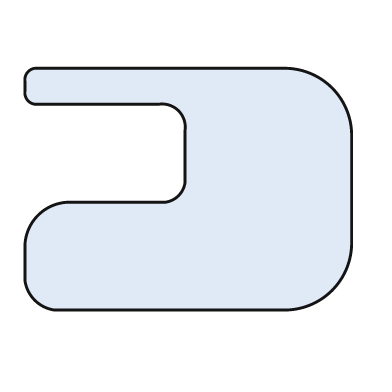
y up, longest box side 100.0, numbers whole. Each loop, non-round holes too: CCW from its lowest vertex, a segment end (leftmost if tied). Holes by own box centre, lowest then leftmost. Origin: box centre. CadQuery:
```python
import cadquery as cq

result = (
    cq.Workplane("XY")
    .moveTo(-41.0, -37.0)
    .lineTo(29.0, -37.0)
    .threePointArc((44.0, -31.0), (50.0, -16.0))
    .lineTo(50.0, 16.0)
    .threePointArc((44.0, 31.0), (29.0, 37.0))
    .lineTo(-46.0, 37.0)
    .threePointArc((-49.0, 36.0), (-50.0, 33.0))
    .lineTo(-50.0, 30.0)
    .threePointArc((-49.0, 27.0), (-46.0, 26.0))
    .lineTo(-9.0, 26.0)
    .threePointArc((-3.0, 24.0), (-1.0, 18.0))
    .lineTo(-1.0, 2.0)
    .threePointArc((-3.0, -2.0), (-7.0, -4.0))
    .lineTo(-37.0, -4.0)
    .threePointArc((-46.0, -8.0), (-50.0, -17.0))
    .lineTo(-50.0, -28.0)
    .threePointArc((-47.0, -34.0), (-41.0, -37.0))
    .close()
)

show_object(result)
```